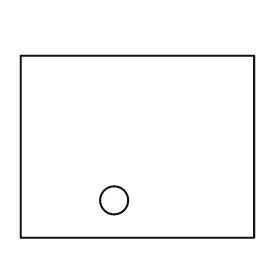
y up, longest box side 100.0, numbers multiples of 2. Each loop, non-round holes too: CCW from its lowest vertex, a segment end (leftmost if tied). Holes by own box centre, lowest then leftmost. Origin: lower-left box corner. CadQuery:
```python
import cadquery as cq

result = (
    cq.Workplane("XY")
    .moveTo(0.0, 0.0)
    .lineTo(100.0, 0.0)
    .lineTo(100.0, 78.0)
    .lineTo(0.0, 78.0)
    .close()
    .moveTo(40.0, 16.0)
    .circle(6.0)
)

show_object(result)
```